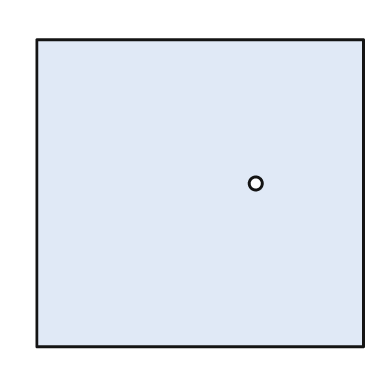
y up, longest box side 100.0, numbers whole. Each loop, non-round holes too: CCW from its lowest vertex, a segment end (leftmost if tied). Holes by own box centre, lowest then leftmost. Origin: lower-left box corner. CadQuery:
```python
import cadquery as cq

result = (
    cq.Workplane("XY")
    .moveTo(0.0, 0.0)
    .lineTo(100.0, 0.0)
    .lineTo(100.0, 94.0)
    .lineTo(0.0, 94.0)
    .close()
    .moveTo(67.0, 50.0)
    .circle(2.0)
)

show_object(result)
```